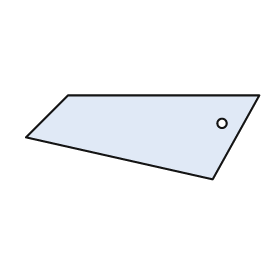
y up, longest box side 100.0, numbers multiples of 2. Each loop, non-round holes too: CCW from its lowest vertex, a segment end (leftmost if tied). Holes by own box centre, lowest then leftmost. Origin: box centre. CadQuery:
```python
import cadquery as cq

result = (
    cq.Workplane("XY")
    .moveTo(30.0, -18.0)
    .lineTo(50.0, 18.0)
    .lineTo(-32.0, 18.0)
    .lineTo(-50.0, 0.0)
    .close()
    .moveTo(34.0, 6.0)
    .circle(2.0)
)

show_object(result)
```